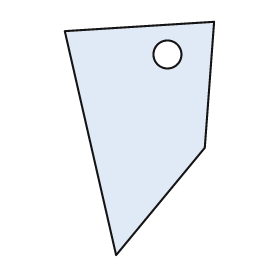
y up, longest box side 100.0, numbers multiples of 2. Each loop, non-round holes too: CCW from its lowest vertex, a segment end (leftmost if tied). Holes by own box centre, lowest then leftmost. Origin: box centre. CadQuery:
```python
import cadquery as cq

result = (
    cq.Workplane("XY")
    .moveTo(-10.0, -50.0)
    .lineTo(28.0, -4.0)
    .lineTo(32.0, 50.0)
    .lineTo(-32.0, 46.0)
    .close()
    .moveTo(12.0, 36.0)
    .circle(6.0)
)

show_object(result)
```